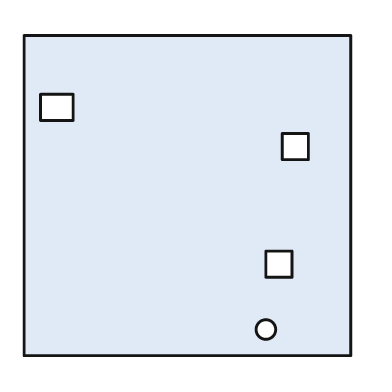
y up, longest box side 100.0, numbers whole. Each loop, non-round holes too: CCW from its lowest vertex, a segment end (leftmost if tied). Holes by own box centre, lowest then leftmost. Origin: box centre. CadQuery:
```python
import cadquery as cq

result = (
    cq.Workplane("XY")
    .moveTo(-50.0, -49.0)
    .lineTo(50.0, -49.0)
    .lineTo(50.0, 49.0)
    .lineTo(-50.0, 49.0)
    .close()
    .moveTo(24.0, -41.0)
    .circle(3.0)
    .moveTo(24.0, -25.0)
    .lineTo(32.0, -25.0)
    .lineTo(32.0, -17.0)
    .lineTo(24.0, -17.0)
    .close()
    .moveTo(29.0, 11.0)
    .lineTo(37.0, 11.0)
    .lineTo(37.0, 19.0)
    .lineTo(29.0, 19.0)
    .close()
    .moveTo(-45.0, 23.0)
    .lineTo(-35.0, 23.0)
    .lineTo(-35.0, 31.0)
    .lineTo(-45.0, 31.0)
    .close()
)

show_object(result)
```